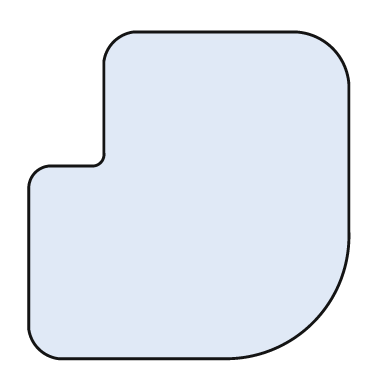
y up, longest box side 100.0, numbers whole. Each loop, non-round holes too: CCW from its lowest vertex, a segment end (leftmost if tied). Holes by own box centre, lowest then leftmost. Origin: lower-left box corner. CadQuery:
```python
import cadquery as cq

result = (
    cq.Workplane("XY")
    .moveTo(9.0, 0.0)
    .lineTo(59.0, 0.0)
    .threePointArc((87.0, 11.0), (98.0, 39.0))
    .lineTo(98.0, 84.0)
    .threePointArc((93.0, 95.0), (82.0, 100.0))
    .lineTo(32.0, 100.0)
    .threePointArc((26.0, 97.0), (23.0, 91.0))
    .lineTo(23.0, 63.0)
    .threePointArc((22.0, 60.0), (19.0, 59.0))
    .lineTo(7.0, 59.0)
    .threePointArc((2.0, 57.0), (0.0, 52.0))
    .lineTo(0.0, 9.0)
    .threePointArc((3.0, 3.0), (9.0, 0.0))
    .close()
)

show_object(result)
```